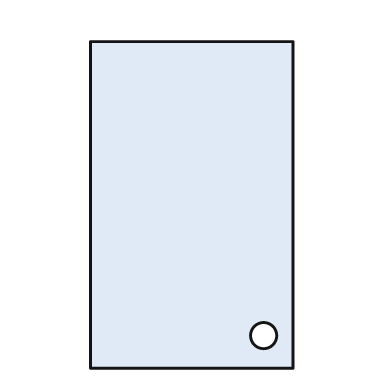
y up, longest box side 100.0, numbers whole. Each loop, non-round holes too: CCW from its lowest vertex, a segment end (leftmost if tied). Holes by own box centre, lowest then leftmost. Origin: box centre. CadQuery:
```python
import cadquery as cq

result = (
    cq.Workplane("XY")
    .moveTo(-31.0, -50.0)
    .lineTo(31.0, -50.0)
    .lineTo(31.0, 50.0)
    .lineTo(-31.0, 50.0)
    .close()
    .moveTo(22.0, -40.0)
    .circle(4.0)
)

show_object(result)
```